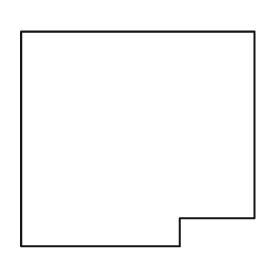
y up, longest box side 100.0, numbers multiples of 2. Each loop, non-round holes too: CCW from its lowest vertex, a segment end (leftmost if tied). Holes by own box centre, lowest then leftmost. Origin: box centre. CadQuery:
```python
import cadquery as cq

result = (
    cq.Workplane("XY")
    .moveTo(-50.0, -46.0)
    .lineTo(18.0, -46.0)
    .lineTo(18.0, -34.0)
    .lineTo(50.0, -34.0)
    .lineTo(50.0, 46.0)
    .lineTo(-50.0, 46.0)
    .close()
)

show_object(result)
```